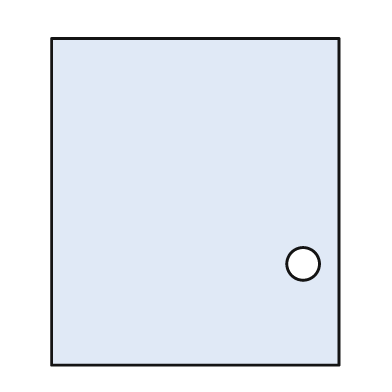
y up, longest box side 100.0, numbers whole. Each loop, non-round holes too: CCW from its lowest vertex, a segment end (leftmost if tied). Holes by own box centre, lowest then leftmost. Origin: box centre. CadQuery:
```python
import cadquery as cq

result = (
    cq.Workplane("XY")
    .moveTo(-44.0, -50.0)
    .lineTo(44.0, -50.0)
    .lineTo(44.0, 50.0)
    .lineTo(-44.0, 50.0)
    .close()
    .moveTo(33.0, -19.0)
    .circle(5.0)
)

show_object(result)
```